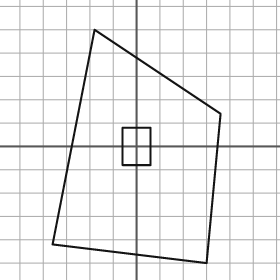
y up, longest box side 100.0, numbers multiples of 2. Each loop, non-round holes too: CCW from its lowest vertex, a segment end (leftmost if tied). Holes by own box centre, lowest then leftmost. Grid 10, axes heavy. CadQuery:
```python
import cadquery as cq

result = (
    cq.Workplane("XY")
    .moveTo(30.0, -50.0)
    .lineTo(36.0, 14.0)
    .lineTo(-18.0, 50.0)
    .lineTo(-36.0, -42.0)
    .close()
    .moveTo(-6.0, -8.0)
    .lineTo(6.0, -8.0)
    .lineTo(6.0, 8.0)
    .lineTo(-6.0, 8.0)
    .close()
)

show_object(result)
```